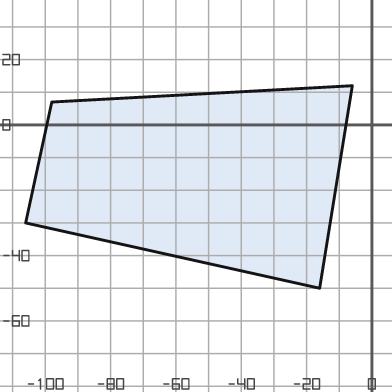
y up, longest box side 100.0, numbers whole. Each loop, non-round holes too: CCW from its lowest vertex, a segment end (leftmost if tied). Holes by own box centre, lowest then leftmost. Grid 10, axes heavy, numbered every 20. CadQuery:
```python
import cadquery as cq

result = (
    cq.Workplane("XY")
    .moveTo(-16.0, -50.0)
    .lineTo(-6.0, 12.0)
    .lineTo(-98.0, 7.0)
    .lineTo(-106.0, -30.0)
    .close()
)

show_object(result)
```